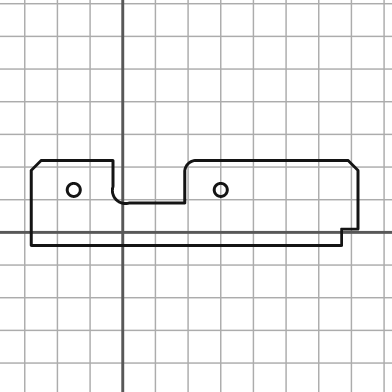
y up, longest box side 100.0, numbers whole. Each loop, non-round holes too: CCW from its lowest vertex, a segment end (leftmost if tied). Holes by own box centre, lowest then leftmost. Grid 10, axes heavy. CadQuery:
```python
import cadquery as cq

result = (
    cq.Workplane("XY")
    .moveTo(-28.0, -4.0)
    .lineTo(67.0, -4.0)
    .lineTo(67.0, 1.0)
    .lineTo(72.0, 1.0)
    .lineTo(72.0, 19.0)
    .lineTo(69.0, 22.0)
    .lineTo(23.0, 22.0)
    .threePointArc((20.0, 21.0), (19.0, 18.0))
    .lineTo(19.0, 9.0)
    .lineTo(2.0, 9.0)
    .threePointArc((-2.0, 10.0), (-3.0, 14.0))
    .lineTo(-3.0, 22.0)
    .lineTo(-25.0, 22.0)
    .lineTo(-28.0, 19.0)
    .close()
    .moveTo(-15.0, 13.0)
    .circle(2.0)
    .moveTo(30.0, 13.0)
    .circle(2.0)
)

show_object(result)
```